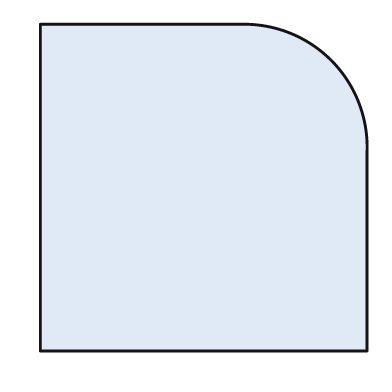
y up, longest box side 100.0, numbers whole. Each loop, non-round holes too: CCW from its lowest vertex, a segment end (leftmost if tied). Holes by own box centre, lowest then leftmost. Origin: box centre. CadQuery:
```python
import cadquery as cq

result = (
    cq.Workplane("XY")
    .moveTo(-50.0, -50.0)
    .lineTo(50.0, -50.0)
    .lineTo(50.0, 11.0)
    .threePointArc((39.0, 39.0), (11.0, 50.0))
    .lineTo(-50.0, 50.0)
    .close()
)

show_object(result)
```